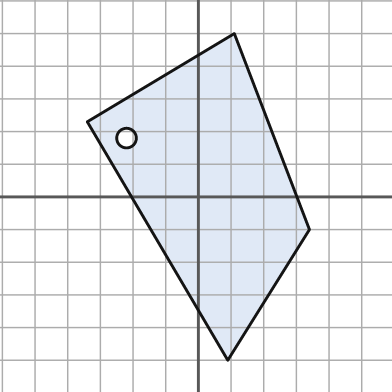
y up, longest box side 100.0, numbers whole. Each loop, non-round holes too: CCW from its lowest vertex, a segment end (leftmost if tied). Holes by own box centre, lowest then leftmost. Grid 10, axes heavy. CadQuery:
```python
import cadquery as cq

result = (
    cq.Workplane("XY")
    .moveTo(9.0, -50.0)
    .lineTo(34.0, -10.0)
    .lineTo(11.0, 50.0)
    .lineTo(-34.0, 23.0)
    .close()
    .moveTo(-22.0, 18.0)
    .circle(3.0)
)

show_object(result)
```